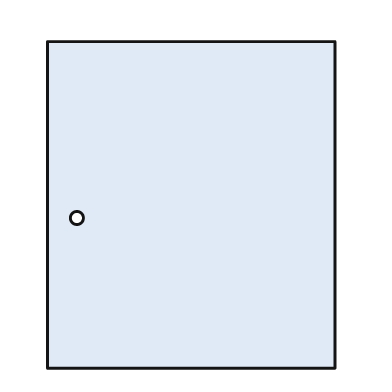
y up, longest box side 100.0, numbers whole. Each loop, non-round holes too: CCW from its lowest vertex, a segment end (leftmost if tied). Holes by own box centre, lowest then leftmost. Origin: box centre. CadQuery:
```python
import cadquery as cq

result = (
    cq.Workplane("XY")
    .moveTo(-44.0, -50.0)
    .lineTo(44.0, -50.0)
    .lineTo(44.0, 50.0)
    .lineTo(-44.0, 50.0)
    .close()
    .moveTo(-35.0, -4.0)
    .circle(2.0)
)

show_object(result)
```